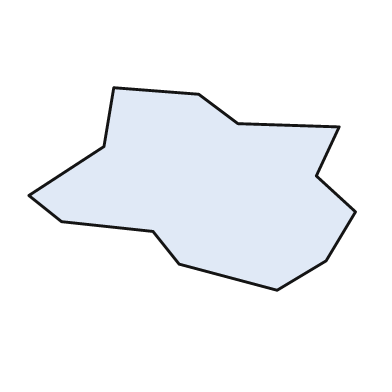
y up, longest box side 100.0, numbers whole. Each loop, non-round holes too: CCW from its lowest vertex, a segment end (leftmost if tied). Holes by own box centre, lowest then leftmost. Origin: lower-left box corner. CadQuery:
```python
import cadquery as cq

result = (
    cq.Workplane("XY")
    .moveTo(76.0, 0.0)
    .lineTo(91.0, 9.0)
    .lineTo(100.0, 24.0)
    .lineTo(88.0, 35.0)
    .lineTo(95.0, 50.0)
    .lineTo(64.0, 51.0)
    .lineTo(52.0, 60.0)
    .lineTo(26.0, 62.0)
    .lineTo(23.0, 44.0)
    .lineTo(0.0, 29.0)
    .lineTo(10.0, 21.0)
    .lineTo(38.0, 18.0)
    .lineTo(46.0, 8.0)
    .close()
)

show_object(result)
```